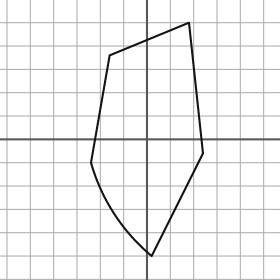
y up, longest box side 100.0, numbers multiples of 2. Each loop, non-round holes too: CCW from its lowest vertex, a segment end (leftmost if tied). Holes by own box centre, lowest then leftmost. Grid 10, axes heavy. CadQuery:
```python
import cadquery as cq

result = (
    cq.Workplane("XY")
    .moveTo(2.0, -50.0)
    .lineTo(24.0, -6.0)
    .lineTo(18.0, 50.0)
    .lineTo(-16.0, 36.0)
    .lineTo(-24.0, -10.0)
    .threePointArc((-14.0, -32.0), (2.0, -50.0))
    .close()
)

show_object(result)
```